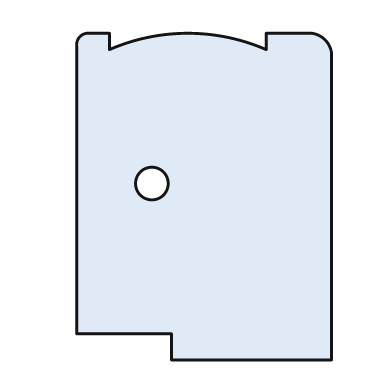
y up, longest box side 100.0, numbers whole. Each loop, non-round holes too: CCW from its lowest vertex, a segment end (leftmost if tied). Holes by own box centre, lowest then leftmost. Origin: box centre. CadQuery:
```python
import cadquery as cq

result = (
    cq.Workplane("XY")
    .moveTo(-10.0, -50.0)
    .lineTo(39.0, -50.0)
    .lineTo(39.0, 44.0)
    .threePointArc((37.0, 48.0), (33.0, 50.0))
    .lineTo(19.0, 50.0)
    .lineTo(19.0, 45.0)
    .threePointArc((-5.0, 50.0), (-29.0, 45.0))
    .lineTo(-29.0, 50.0)
    .lineTo(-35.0, 50.0)
    .threePointArc((-38.0, 49.0), (-39.0, 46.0))
    .lineTo(-39.0, -42.0)
    .lineTo(-10.0, -42.0)
    .close()
    .moveTo(-16.0, 4.0)
    .circle(5.0)
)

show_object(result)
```